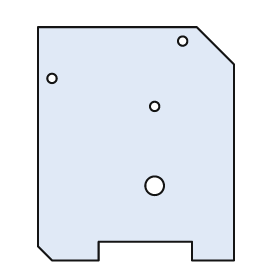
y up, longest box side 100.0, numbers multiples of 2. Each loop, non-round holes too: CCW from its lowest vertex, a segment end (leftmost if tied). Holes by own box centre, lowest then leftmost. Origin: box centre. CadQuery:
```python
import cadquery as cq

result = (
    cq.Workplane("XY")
    .moveTo(-36.0, -50.0)
    .lineTo(-16.0, -50.0)
    .lineTo(-16.0, -42.0)
    .lineTo(24.0, -42.0)
    .lineTo(24.0, -50.0)
    .lineTo(42.0, -50.0)
    .lineTo(42.0, 34.0)
    .lineTo(26.0, 50.0)
    .lineTo(-42.0, 50.0)
    .lineTo(-42.0, -44.0)
    .close()
    .moveTo(8.0, -18.0)
    .circle(4.0)
    .moveTo(8.0, 16.0)
    .circle(2.0)
    .moveTo(-36.0, 28.0)
    .circle(2.0)
    .moveTo(20.0, 44.0)
    .circle(2.0)
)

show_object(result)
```